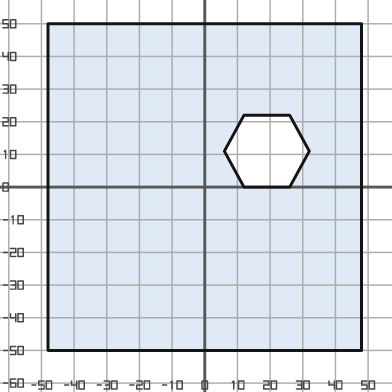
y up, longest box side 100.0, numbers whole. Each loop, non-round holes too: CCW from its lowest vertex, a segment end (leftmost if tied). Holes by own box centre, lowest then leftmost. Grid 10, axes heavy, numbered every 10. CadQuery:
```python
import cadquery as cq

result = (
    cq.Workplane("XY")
    .moveTo(-48.0, -50.0)
    .lineTo(48.0, -50.0)
    .lineTo(48.0, 50.0)
    .lineTo(-48.0, 50.0)
    .close()
    .moveTo(12.0, 0.0)
    .lineTo(26.0, 0.0)
    .lineTo(32.0, 11.0)
    .lineTo(26.0, 22.0)
    .lineTo(12.0, 22.0)
    .lineTo(6.0, 11.0)
    .close()
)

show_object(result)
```